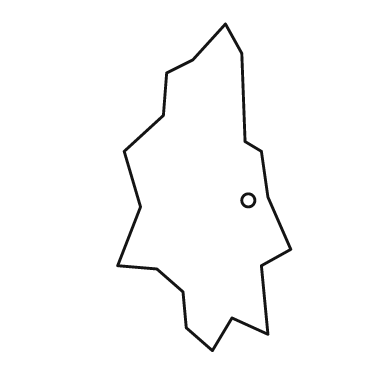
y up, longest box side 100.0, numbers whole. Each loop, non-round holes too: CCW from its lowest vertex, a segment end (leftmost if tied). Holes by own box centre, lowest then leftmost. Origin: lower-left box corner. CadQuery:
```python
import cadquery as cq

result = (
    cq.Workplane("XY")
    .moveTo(29.0, 0.0)
    .lineTo(35.0, 10.0)
    .lineTo(46.0, 5.0)
    .lineTo(44.0, 26.0)
    .lineTo(53.0, 31.0)
    .lineTo(46.0, 47.0)
    .lineTo(44.0, 61.0)
    .lineTo(39.0, 64.0)
    .lineTo(38.0, 91.0)
    .lineTo(33.0, 100.0)
    .lineTo(23.0, 89.0)
    .lineTo(15.0, 85.0)
    .lineTo(14.0, 72.0)
    .lineTo(2.0, 61.0)
    .lineTo(7.0, 44.0)
    .lineTo(0.0, 26.0)
    .lineTo(12.0, 25.0)
    .lineTo(20.0, 18.0)
    .lineTo(21.0, 7.0)
    .close()
    .moveTo(40.0, 46.0)
    .circle(2.0)
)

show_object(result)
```